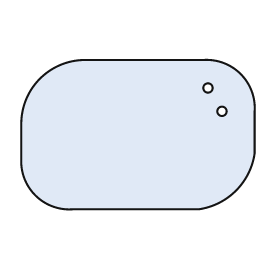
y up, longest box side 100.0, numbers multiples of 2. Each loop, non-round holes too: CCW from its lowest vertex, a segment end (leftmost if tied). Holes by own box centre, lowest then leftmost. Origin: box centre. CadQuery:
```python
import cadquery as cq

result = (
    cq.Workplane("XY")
    .moveTo(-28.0, -32.0)
    .lineTo(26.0, -32.0)
    .threePointArc((42.0, -24.0), (50.0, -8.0))
    .lineTo(50.0, 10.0)
    .threePointArc((44.0, 26.0), (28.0, 32.0))
    .lineTo(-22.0, 32.0)
    .threePointArc((-42.0, 24.0), (-50.0, 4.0))
    .lineTo(-50.0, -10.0)
    .threePointArc((-44.0, -26.0), (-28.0, -32.0))
    .close()
    .moveTo(36.0, 10.0)
    .circle(2.0)
    .moveTo(30.0, 20.0)
    .circle(2.0)
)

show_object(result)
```